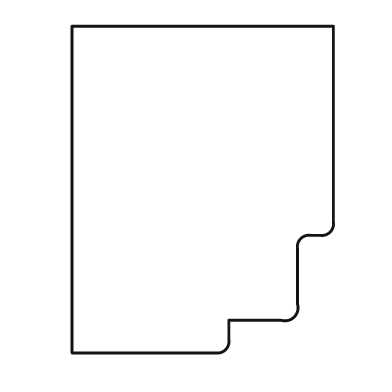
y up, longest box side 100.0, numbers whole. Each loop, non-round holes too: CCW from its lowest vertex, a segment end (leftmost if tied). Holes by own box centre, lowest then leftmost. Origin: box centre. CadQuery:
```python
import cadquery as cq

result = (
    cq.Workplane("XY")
    .moveTo(-40.0, -50.0)
    .lineTo(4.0, -50.0)
    .threePointArc((7.0, -49.0), (8.0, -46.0))
    .lineTo(8.0, -40.0)
    .lineTo(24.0, -40.0)
    .threePointArc((28.0, -39.0), (29.0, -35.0))
    .lineTo(29.0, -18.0)
    .threePointArc((30.0, -15.0), (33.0, -14.0))
    .lineTo(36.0, -14.0)
    .threePointArc((39.0, -13.0), (40.0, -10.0))
    .lineTo(40.0, 50.0)
    .lineTo(-40.0, 50.0)
    .close()
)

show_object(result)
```